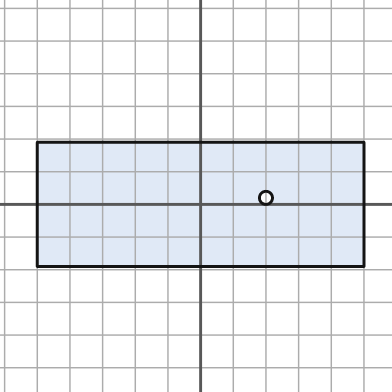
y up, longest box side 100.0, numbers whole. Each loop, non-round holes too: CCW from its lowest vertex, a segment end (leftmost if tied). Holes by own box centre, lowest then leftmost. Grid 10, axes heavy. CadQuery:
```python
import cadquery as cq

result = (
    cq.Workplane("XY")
    .moveTo(-50.0, -19.0)
    .lineTo(50.0, -19.0)
    .lineTo(50.0, 19.0)
    .lineTo(-50.0, 19.0)
    .close()
    .moveTo(20.0, 2.0)
    .circle(2.0)
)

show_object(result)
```